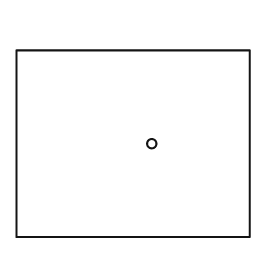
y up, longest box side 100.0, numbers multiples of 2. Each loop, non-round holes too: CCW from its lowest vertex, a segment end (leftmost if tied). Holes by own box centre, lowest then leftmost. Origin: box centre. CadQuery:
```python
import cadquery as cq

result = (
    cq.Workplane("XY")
    .moveTo(-50.0, -40.0)
    .lineTo(50.0, -40.0)
    .lineTo(50.0, 40.0)
    .lineTo(-50.0, 40.0)
    .close()
    .moveTo(8.0, 0.0)
    .circle(2.0)
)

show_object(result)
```